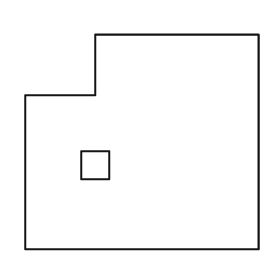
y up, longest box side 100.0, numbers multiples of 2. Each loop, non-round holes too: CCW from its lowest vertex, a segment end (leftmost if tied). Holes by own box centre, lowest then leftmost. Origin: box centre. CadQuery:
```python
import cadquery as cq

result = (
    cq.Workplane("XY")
    .moveTo(-50.0, -46.0)
    .lineTo(50.0, -46.0)
    .lineTo(50.0, 46.0)
    .lineTo(-20.0, 46.0)
    .lineTo(-20.0, 20.0)
    .lineTo(-50.0, 20.0)
    .close()
    .moveTo(-26.0, -16.0)
    .lineTo(-14.0, -16.0)
    .lineTo(-14.0, -4.0)
    .lineTo(-26.0, -4.0)
    .close()
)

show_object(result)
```